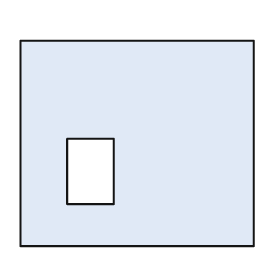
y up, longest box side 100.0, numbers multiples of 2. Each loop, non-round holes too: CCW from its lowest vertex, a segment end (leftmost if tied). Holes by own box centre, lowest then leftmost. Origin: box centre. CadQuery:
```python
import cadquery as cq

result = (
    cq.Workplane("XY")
    .moveTo(-50.0, -44.0)
    .lineTo(50.0, -44.0)
    .lineTo(50.0, 44.0)
    .lineTo(-50.0, 44.0)
    .close()
    .moveTo(-30.0, -26.0)
    .lineTo(-10.0, -26.0)
    .lineTo(-10.0, 2.0)
    .lineTo(-30.0, 2.0)
    .close()
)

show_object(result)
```